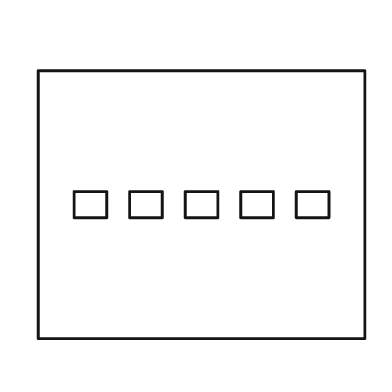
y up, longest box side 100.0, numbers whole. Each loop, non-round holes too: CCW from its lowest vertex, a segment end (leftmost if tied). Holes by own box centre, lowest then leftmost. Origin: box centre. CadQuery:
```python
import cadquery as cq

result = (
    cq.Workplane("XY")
    .moveTo(-50.0, -41.0)
    .lineTo(50.0, -41.0)
    .lineTo(50.0, 41.0)
    .lineTo(-50.0, 41.0)
    .close()
    .moveTo(-39.0, -4.0)
    .lineTo(-29.0, -4.0)
    .lineTo(-29.0, 4.0)
    .lineTo(-39.0, 4.0)
    .close()
    .moveTo(-22.0, -4.0)
    .lineTo(-12.0, -4.0)
    .lineTo(-12.0, 4.0)
    .lineTo(-22.0, 4.0)
    .close()
    .moveTo(-5.0, -4.0)
    .lineTo(5.0, -4.0)
    .lineTo(5.0, 4.0)
    .lineTo(-5.0, 4.0)
    .close()
    .moveTo(12.0, -4.0)
    .lineTo(22.0, -4.0)
    .lineTo(22.0, 4.0)
    .lineTo(12.0, 4.0)
    .close()
    .moveTo(29.0, -4.0)
    .lineTo(39.0, -4.0)
    .lineTo(39.0, 4.0)
    .lineTo(29.0, 4.0)
    .close()
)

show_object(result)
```